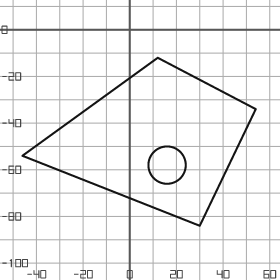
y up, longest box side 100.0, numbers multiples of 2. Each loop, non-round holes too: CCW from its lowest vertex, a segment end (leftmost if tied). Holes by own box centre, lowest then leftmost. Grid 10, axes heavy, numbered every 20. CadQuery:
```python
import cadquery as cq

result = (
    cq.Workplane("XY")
    .moveTo(30.0, -84.0)
    .lineTo(54.0, -34.0)
    .lineTo(12.0, -12.0)
    .lineTo(-46.0, -54.0)
    .close()
    .moveTo(16.0, -58.0)
    .circle(8.0)
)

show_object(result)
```